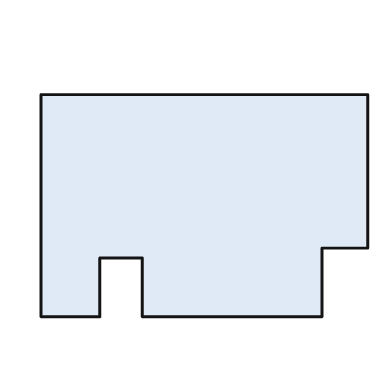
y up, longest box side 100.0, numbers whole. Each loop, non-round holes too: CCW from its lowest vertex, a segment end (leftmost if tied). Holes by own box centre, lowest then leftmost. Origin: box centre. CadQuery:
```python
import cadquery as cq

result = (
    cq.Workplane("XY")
    .moveTo(-50.0, -34.0)
    .lineTo(-32.0, -34.0)
    .lineTo(-32.0, -16.0)
    .lineTo(-19.0, -16.0)
    .lineTo(-19.0, -34.0)
    .lineTo(36.0, -34.0)
    .lineTo(36.0, -13.0)
    .lineTo(50.0, -13.0)
    .lineTo(50.0, 34.0)
    .lineTo(-50.0, 34.0)
    .close()
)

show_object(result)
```